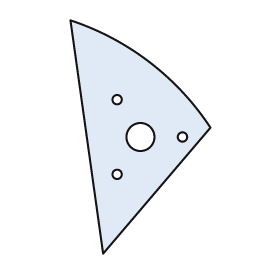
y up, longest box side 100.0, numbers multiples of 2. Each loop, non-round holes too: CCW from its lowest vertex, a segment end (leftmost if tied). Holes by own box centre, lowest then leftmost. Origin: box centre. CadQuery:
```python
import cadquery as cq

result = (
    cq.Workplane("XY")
    .moveTo(-16.0, -50.0)
    .lineTo(30.0, 4.0)
    .threePointArc((4.0, 32.0), (-30.0, 50.0))
    .close()
    .moveTo(-10.0, -16.0)
    .circle(2.0)
    .moveTo(0.0, 0.0)
    .circle(6.0)
    .moveTo(18.0, 0.0)
    .circle(2.0)
    .moveTo(-10.0, 16.0)
    .circle(2.0)
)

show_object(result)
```